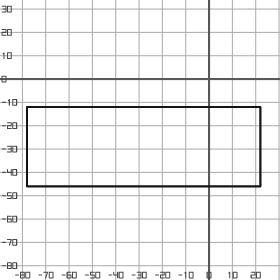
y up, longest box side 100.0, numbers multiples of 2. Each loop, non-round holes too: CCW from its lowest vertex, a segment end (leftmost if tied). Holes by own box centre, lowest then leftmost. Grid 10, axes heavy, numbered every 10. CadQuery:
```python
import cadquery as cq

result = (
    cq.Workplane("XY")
    .moveTo(-78.0, -46.0)
    .lineTo(22.0, -46.0)
    .lineTo(22.0, -12.0)
    .lineTo(-78.0, -12.0)
    .close()
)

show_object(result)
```